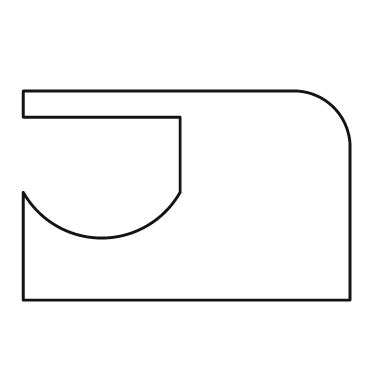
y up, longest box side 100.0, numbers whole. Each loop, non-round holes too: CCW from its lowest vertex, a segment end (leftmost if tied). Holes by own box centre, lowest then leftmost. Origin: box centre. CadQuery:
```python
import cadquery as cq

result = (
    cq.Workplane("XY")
    .moveTo(-50.0, -32.0)
    .lineTo(50.0, -32.0)
    .lineTo(50.0, 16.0)
    .threePointArc((45.0, 27.0), (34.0, 32.0))
    .lineTo(-50.0, 32.0)
    .lineTo(-50.0, 24.0)
    .lineTo(-2.0, 24.0)
    .lineTo(-2.0, 1.0)
    .threePointArc((-26.0, -13.0), (-50.0, 1.0))
    .close()
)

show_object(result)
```